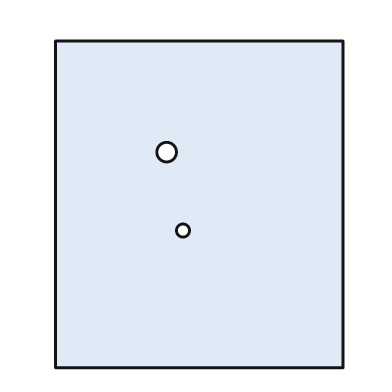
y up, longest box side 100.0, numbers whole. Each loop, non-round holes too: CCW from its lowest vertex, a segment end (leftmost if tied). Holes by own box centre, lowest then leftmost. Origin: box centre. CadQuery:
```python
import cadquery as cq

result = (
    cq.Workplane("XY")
    .moveTo(-44.0, -50.0)
    .lineTo(44.0, -50.0)
    .lineTo(44.0, 50.0)
    .lineTo(-44.0, 50.0)
    .close()
    .moveTo(-5.0, -8.0)
    .circle(2.0)
    .moveTo(-10.0, 16.0)
    .circle(3.0)
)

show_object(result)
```